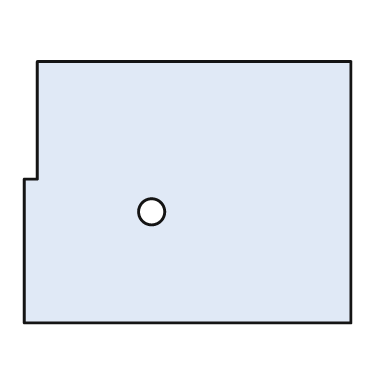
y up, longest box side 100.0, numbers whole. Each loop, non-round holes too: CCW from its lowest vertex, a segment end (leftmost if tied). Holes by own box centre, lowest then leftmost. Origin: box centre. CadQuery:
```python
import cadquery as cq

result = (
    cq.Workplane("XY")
    .moveTo(-50.0, -40.0)
    .lineTo(50.0, -40.0)
    .lineTo(50.0, 40.0)
    .lineTo(-46.0, 40.0)
    .lineTo(-46.0, 4.0)
    .lineTo(-50.0, 4.0)
    .close()
    .moveTo(-11.0, -6.0)
    .circle(4.0)
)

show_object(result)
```